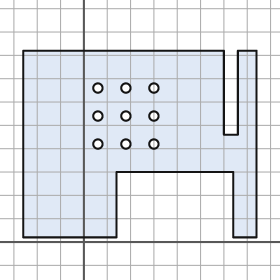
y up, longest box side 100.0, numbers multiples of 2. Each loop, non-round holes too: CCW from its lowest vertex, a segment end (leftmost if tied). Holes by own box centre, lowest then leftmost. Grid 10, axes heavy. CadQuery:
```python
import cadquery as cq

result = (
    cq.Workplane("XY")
    .moveTo(-26.0, 2.0)
    .lineTo(14.0, 2.0)
    .lineTo(14.0, 30.0)
    .lineTo(64.0, 30.0)
    .lineTo(64.0, 2.0)
    .lineTo(74.0, 2.0)
    .lineTo(74.0, 82.0)
    .lineTo(66.0, 82.0)
    .lineTo(66.0, 46.0)
    .lineTo(60.0, 46.0)
    .lineTo(60.0, 82.0)
    .lineTo(-26.0, 82.0)
    .close()
    .moveTo(6.0, 42.0)
    .circle(2.0)
    .moveTo(18.0, 42.0)
    .circle(2.0)
    .moveTo(30.0, 42.0)
    .circle(2.0)
    .moveTo(6.0, 54.0)
    .circle(2.0)
    .moveTo(18.0, 54.0)
    .circle(2.0)
    .moveTo(30.0, 54.0)
    .circle(2.0)
    .moveTo(6.0, 66.0)
    .circle(2.0)
    .moveTo(18.0, 66.0)
    .circle(2.0)
    .moveTo(30.0, 66.0)
    .circle(2.0)
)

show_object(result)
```